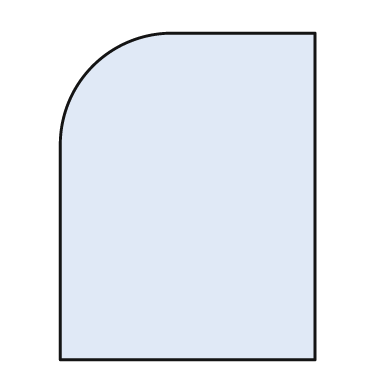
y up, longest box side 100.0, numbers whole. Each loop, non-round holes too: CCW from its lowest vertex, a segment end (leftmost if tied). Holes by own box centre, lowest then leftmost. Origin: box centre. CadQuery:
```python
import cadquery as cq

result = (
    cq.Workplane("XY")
    .moveTo(-39.0, -50.0)
    .lineTo(39.0, -50.0)
    .lineTo(39.0, 50.0)
    .lineTo(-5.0, 50.0)
    .threePointArc((-29.0, 40.0), (-39.0, 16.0))
    .close()
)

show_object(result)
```